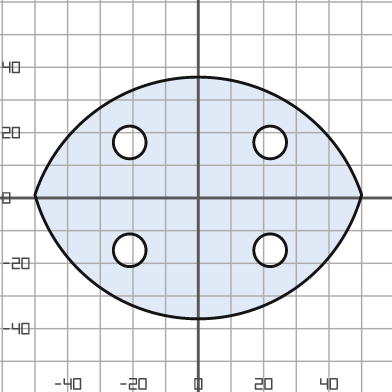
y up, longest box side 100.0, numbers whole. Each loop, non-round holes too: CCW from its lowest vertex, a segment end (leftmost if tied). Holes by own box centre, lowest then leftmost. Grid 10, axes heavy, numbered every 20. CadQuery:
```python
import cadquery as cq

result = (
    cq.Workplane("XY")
    .moveTo(-50.0, 1.0)
    .threePointArc((0.0, -37.0), (50.0, 1.0))
    .threePointArc((0.0, 37.0), (-50.0, 1.0))
    .close()
    .moveTo(-21.0, -16.0)
    .circle(5.0)
    .moveTo(22.0, -16.0)
    .circle(5.0)
    .moveTo(-21.0, 17.0)
    .circle(5.0)
    .moveTo(22.0, 17.0)
    .circle(5.0)
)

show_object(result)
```